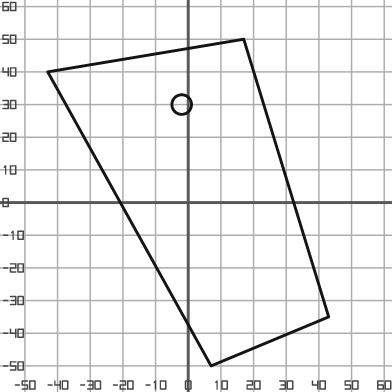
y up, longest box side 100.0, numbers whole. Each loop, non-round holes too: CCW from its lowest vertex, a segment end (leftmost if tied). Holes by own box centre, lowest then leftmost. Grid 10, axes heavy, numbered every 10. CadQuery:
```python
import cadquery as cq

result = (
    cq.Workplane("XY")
    .moveTo(7.0, -50.0)
    .lineTo(43.0, -35.0)
    .lineTo(17.0, 50.0)
    .lineTo(-43.0, 40.0)
    .close()
    .moveTo(-2.0, 30.0)
    .circle(3.0)
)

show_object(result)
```